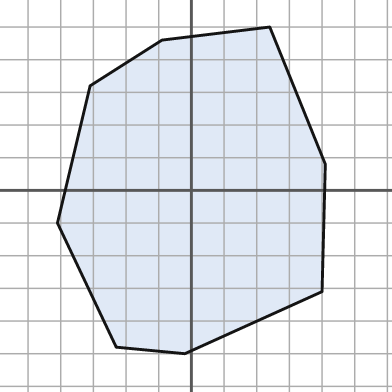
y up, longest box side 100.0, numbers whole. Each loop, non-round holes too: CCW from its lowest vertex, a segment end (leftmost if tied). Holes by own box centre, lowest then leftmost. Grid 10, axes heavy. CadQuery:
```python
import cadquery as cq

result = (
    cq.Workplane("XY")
    .moveTo(-2.0, -50.0)
    .lineTo(40.0, -31.0)
    .lineTo(41.0, 8.0)
    .lineTo(24.0, 50.0)
    .lineTo(-9.0, 46.0)
    .lineTo(-31.0, 32.0)
    .lineTo(-41.0, -10.0)
    .lineTo(-23.0, -48.0)
    .close()
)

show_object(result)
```